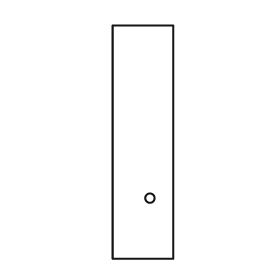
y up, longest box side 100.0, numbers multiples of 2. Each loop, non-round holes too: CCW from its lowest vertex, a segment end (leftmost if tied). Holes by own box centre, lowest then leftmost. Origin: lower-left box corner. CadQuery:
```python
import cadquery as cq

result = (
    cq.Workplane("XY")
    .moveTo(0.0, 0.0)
    .lineTo(26.0, 0.0)
    .lineTo(26.0, 100.0)
    .lineTo(0.0, 100.0)
    .close()
    .moveTo(16.0, 26.0)
    .circle(2.0)
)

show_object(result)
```